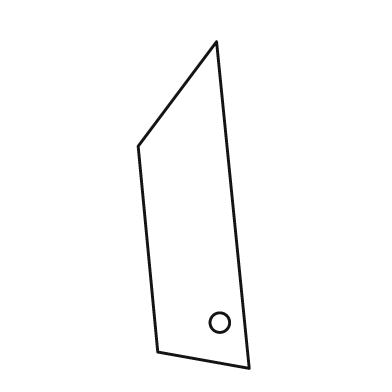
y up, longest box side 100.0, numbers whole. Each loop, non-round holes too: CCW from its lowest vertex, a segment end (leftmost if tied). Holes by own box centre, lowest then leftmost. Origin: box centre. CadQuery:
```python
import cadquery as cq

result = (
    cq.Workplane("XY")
    .moveTo(17.0, -50.0)
    .lineTo(7.0, 50.0)
    .lineTo(-17.0, 18.0)
    .lineTo(-11.0, -45.0)
    .close()
    .moveTo(8.0, -36.0)
    .circle(3.0)
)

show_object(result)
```